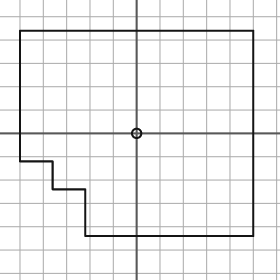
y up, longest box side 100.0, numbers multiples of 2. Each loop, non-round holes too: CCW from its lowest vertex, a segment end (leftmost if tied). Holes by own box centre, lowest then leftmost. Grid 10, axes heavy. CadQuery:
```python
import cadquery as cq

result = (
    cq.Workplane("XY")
    .moveTo(-22.0, -44.0)
    .lineTo(50.0, -44.0)
    .lineTo(50.0, 44.0)
    .lineTo(-50.0, 44.0)
    .lineTo(-50.0, -12.0)
    .lineTo(-36.0, -12.0)
    .lineTo(-36.0, -24.0)
    .lineTo(-22.0, -24.0)
    .close()
    .moveTo(0.0, 0.0)
    .circle(2.0)
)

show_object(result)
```